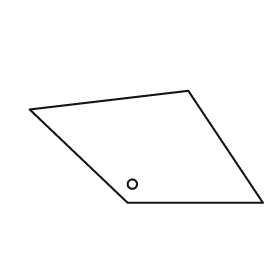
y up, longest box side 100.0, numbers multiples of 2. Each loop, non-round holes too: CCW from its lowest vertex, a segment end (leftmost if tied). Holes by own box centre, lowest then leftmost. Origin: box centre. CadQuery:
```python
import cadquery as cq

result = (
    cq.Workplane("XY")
    .moveTo(-8.0, -24.0)
    .lineTo(50.0, -24.0)
    .lineTo(18.0, 24.0)
    .lineTo(-50.0, 16.0)
    .close()
    .moveTo(-6.0, -16.0)
    .circle(2.0)
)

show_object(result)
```